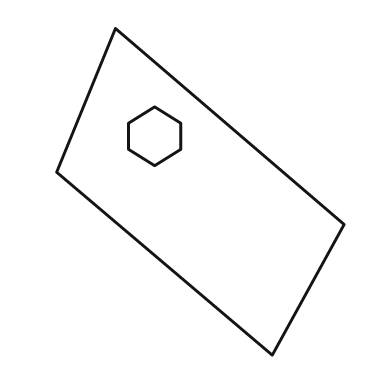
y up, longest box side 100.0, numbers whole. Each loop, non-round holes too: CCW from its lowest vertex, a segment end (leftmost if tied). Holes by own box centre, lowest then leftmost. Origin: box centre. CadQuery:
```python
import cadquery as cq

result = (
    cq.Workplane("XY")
    .moveTo(22.0, -50.0)
    .lineTo(44.0, -10.0)
    .lineTo(-26.0, 50.0)
    .lineTo(-44.0, 6.0)
    .close()
    .moveTo(-14.0, 8.0)
    .lineTo(-6.0, 13.0)
    .lineTo(-6.0, 21.0)
    .lineTo(-14.0, 26.0)
    .lineTo(-22.0, 21.0)
    .lineTo(-22.0, 13.0)
    .close()
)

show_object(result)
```